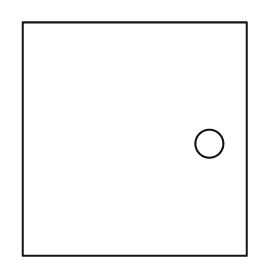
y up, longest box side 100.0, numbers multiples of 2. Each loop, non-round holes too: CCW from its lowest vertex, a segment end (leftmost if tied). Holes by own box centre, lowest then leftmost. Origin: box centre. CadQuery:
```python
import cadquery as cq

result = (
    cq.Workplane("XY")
    .moveTo(-48.0, -50.0)
    .lineTo(48.0, -50.0)
    .lineTo(48.0, 50.0)
    .lineTo(-48.0, 50.0)
    .close()
    .moveTo(32.0, -2.0)
    .circle(6.0)
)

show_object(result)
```